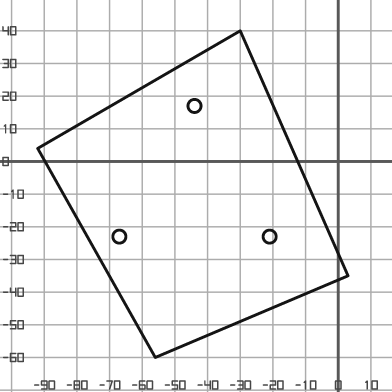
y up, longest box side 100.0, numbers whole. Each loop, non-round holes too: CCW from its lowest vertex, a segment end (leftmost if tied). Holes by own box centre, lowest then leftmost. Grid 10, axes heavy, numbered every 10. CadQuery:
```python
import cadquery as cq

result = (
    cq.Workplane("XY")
    .moveTo(-56.0, -60.0)
    .lineTo(3.0, -35.0)
    .lineTo(-30.0, 40.0)
    .lineTo(-92.0, 4.0)
    .close()
    .moveTo(-67.0, -23.0)
    .circle(2.0)
    .moveTo(-21.0, -23.0)
    .circle(2.0)
    .moveTo(-44.0, 17.0)
    .circle(2.0)
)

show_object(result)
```